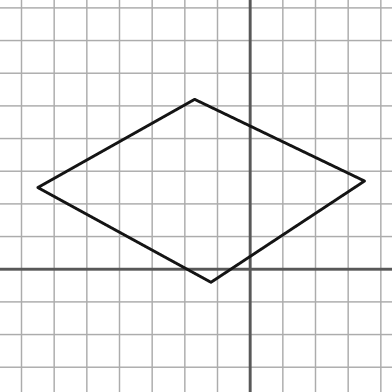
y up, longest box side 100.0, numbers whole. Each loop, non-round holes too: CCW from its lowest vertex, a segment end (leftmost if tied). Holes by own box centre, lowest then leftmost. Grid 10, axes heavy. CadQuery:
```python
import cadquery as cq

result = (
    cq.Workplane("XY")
    .moveTo(-12.0, -4.0)
    .lineTo(35.0, 27.0)
    .lineTo(-17.0, 52.0)
    .lineTo(-65.0, 25.0)
    .close()
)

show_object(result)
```